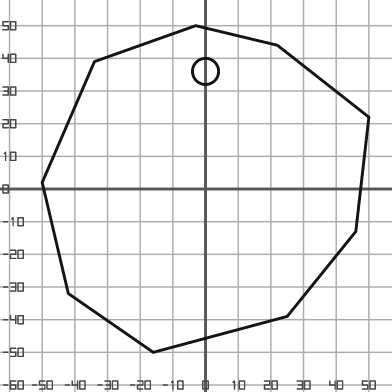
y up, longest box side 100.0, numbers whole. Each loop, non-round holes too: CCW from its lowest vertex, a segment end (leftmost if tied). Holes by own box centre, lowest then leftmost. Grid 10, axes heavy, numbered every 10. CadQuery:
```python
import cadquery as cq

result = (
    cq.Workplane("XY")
    .moveTo(-16.0, -50.0)
    .lineTo(25.0, -39.0)
    .lineTo(46.0, -13.0)
    .lineTo(50.0, 22.0)
    .lineTo(22.0, 44.0)
    .lineTo(-3.0, 50.0)
    .lineTo(-34.0, 39.0)
    .lineTo(-50.0, 2.0)
    .lineTo(-42.0, -32.0)
    .close()
    .moveTo(0.0, 36.0)
    .circle(4.0)
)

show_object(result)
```